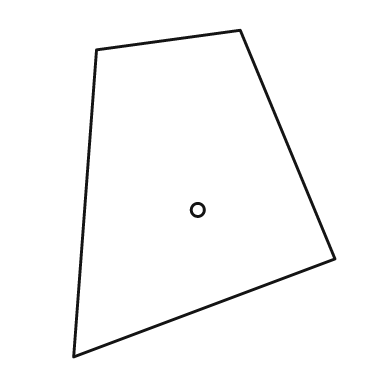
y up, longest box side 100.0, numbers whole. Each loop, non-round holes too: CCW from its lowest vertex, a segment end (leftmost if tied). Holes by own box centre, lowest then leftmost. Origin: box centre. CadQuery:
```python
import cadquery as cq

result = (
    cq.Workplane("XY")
    .moveTo(-40.0, -50.0)
    .lineTo(40.0, -20.0)
    .lineTo(11.0, 50.0)
    .lineTo(-33.0, 44.0)
    .close()
    .moveTo(-2.0, -5.0)
    .circle(2.0)
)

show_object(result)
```